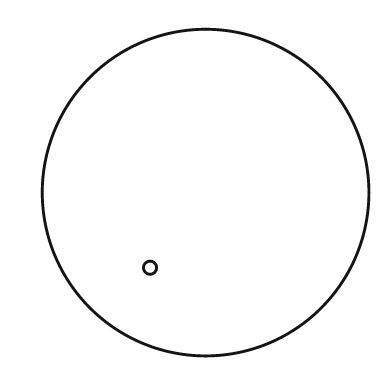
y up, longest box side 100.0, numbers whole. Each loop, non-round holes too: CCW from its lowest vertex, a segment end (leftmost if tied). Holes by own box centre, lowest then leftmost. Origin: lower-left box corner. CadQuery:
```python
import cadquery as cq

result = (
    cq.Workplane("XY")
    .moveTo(50.0, 50.0)
    .circle(50.0)
    .moveTo(33.0, 27.0)
    .circle(2.0)
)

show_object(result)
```